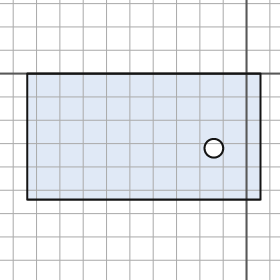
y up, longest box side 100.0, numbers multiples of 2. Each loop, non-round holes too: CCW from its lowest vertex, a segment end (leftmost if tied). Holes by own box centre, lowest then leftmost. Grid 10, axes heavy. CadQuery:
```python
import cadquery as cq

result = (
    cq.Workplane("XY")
    .moveTo(-94.0, -54.0)
    .lineTo(6.0, -54.0)
    .lineTo(6.0, 0.0)
    .lineTo(-94.0, 0.0)
    .close()
    .moveTo(-14.0, -32.0)
    .circle(4.0)
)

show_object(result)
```